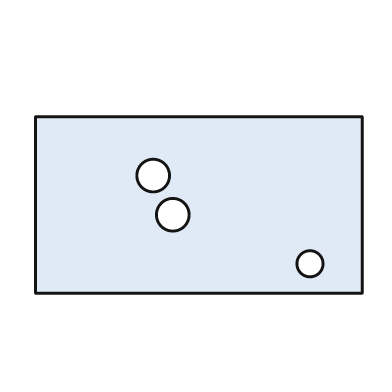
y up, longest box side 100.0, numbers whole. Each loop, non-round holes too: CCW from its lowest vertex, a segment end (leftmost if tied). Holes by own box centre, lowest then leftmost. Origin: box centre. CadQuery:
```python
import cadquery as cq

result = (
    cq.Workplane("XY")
    .moveTo(-50.0, -27.0)
    .lineTo(50.0, -27.0)
    .lineTo(50.0, 27.0)
    .lineTo(-50.0, 27.0)
    .close()
    .moveTo(34.0, -18.0)
    .circle(4.0)
    .moveTo(-8.0, -3.0)
    .circle(5.0)
    .moveTo(-14.0, 9.0)
    .circle(5.0)
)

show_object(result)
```